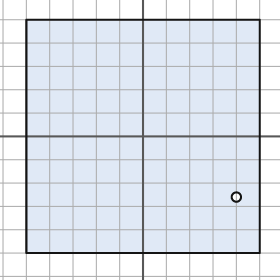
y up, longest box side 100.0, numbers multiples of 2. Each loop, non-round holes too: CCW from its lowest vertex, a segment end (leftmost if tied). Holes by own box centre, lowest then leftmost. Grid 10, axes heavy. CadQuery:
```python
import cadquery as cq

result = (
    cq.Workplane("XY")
    .moveTo(-50.0, -50.0)
    .lineTo(50.0, -50.0)
    .lineTo(50.0, 50.0)
    .lineTo(-50.0, 50.0)
    .close()
    .moveTo(40.0, -26.0)
    .circle(2.0)
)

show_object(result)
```